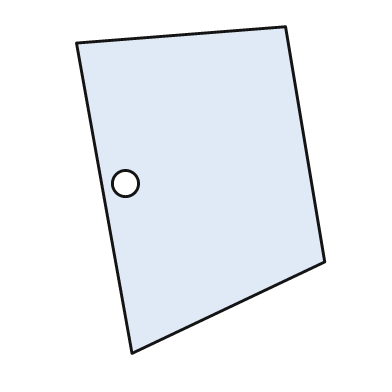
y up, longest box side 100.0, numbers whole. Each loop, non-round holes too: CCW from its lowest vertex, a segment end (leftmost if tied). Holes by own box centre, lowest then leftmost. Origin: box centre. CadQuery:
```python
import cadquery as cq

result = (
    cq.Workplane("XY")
    .moveTo(-21.0, -50.0)
    .lineTo(38.0, -22.0)
    .lineTo(26.0, 50.0)
    .lineTo(-38.0, 45.0)
    .close()
    .moveTo(-23.0, 2.0)
    .circle(4.0)
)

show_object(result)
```